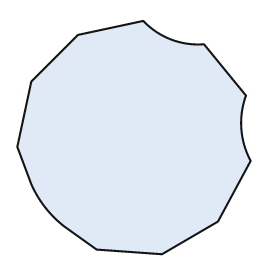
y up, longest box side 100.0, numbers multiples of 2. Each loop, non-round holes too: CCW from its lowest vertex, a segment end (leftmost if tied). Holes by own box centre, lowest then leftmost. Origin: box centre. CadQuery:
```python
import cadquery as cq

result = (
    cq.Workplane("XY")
    .moveTo(12.0, -50.0)
    .lineTo(36.0, -36.0)
    .lineTo(50.0, -10.0)
    .threePointArc((46.0, 4.0), (48.0, 18.0))
    .lineTo(30.0, 40.0)
    .threePointArc((16.0, 42.0), (4.0, 50.0))
    .lineTo(-24.0, 44.0)
    .lineTo(-44.0, 24.0)
    .lineTo(-50.0, -4.0)
    .lineTo(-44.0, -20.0)
    .threePointArc((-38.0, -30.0), (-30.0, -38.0))
    .lineTo(-16.0, -48.0)
    .close()
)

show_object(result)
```